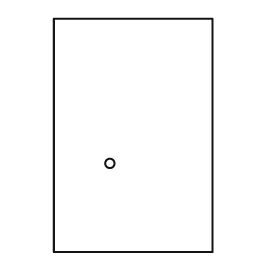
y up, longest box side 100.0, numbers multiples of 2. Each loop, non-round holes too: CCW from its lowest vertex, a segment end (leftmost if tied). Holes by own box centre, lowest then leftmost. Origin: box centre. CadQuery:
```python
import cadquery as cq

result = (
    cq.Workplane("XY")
    .moveTo(-34.0, -50.0)
    .lineTo(34.0, -50.0)
    .lineTo(34.0, 50.0)
    .lineTo(-34.0, 50.0)
    .close()
    .moveTo(-10.0, -12.0)
    .circle(2.0)
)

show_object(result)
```